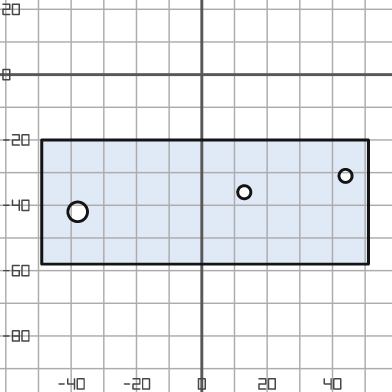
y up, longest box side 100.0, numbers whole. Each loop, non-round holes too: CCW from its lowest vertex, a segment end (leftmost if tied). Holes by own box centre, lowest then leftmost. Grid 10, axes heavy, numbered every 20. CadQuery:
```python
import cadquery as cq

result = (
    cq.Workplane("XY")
    .moveTo(-49.0, -58.0)
    .lineTo(51.0, -58.0)
    .lineTo(51.0, -20.0)
    .lineTo(-49.0, -20.0)
    .close()
    .moveTo(-38.0, -42.0)
    .circle(3.0)
    .moveTo(13.0, -36.0)
    .circle(2.0)
    .moveTo(44.0, -31.0)
    .circle(2.0)
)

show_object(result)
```